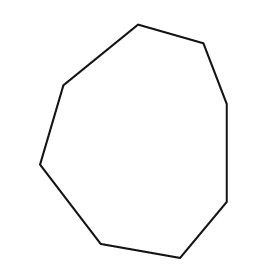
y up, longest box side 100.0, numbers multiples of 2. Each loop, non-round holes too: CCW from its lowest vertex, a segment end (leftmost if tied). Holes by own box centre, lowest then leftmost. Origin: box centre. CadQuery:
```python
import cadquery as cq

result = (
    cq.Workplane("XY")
    .moveTo(20.0, -50.0)
    .lineTo(40.0, -26.0)
    .lineTo(40.0, 16.0)
    .lineTo(30.0, 42.0)
    .lineTo(2.0, 50.0)
    .lineTo(-30.0, 24.0)
    .lineTo(-40.0, -10.0)
    .lineTo(-14.0, -44.0)
    .close()
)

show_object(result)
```